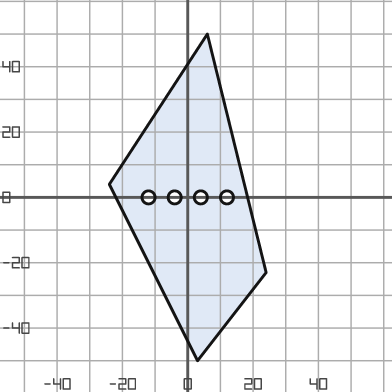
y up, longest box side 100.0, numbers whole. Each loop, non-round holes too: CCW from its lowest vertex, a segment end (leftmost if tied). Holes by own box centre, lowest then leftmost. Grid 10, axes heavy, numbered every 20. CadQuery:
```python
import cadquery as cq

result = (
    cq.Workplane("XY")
    .moveTo(3.0, -50.0)
    .lineTo(24.0, -23.0)
    .lineTo(6.0, 50.0)
    .lineTo(-24.0, 4.0)
    .close()
    .moveTo(-12.0, 0.0)
    .circle(2.0)
    .moveTo(-4.0, 0.0)
    .circle(2.0)
    .moveTo(4.0, 0.0)
    .circle(2.0)
    .moveTo(12.0, 0.0)
    .circle(2.0)
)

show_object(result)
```